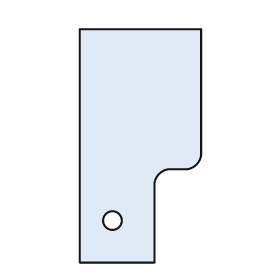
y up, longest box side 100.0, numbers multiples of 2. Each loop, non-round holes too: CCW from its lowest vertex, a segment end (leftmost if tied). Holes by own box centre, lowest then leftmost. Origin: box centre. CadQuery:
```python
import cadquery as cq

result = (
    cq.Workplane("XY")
    .moveTo(-26.0, -50.0)
    .lineTo(6.0, -50.0)
    .lineTo(6.0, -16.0)
    .threePointArc((8.0, -12.0), (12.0, -10.0))
    .lineTo(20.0, -10.0)
    .threePointArc((24.0, -8.0), (26.0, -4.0))
    .lineTo(26.0, 50.0)
    .lineTo(-26.0, 50.0)
    .close()
    .moveTo(-12.0, -32.0)
    .circle(4.0)
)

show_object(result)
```